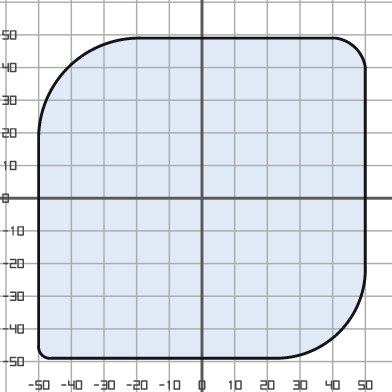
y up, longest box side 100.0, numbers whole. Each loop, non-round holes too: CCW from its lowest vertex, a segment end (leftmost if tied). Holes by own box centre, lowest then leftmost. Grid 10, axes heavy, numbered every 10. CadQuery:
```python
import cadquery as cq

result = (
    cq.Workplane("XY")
    .moveTo(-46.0, -49.0)
    .lineTo(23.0, -49.0)
    .threePointArc((42.0, -41.0), (50.0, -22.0))
    .lineTo(50.0, 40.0)
    .threePointArc((47.0, 46.0), (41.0, 49.0))
    .lineTo(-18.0, 49.0)
    .threePointArc((-41.0, 40.0), (-50.0, 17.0))
    .lineTo(-50.0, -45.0)
    .threePointArc((-49.0, -48.0), (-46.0, -49.0))
    .close()
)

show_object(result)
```